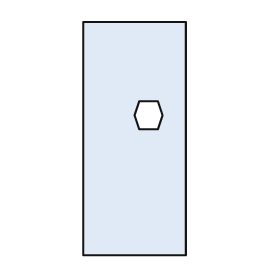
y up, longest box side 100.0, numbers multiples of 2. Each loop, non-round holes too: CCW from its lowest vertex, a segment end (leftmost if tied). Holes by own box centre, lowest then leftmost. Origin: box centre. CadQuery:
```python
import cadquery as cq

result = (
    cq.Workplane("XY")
    .moveTo(-22.0, -50.0)
    .lineTo(22.0, -50.0)
    .lineTo(22.0, 50.0)
    .lineTo(-22.0, 50.0)
    .close()
    .moveTo(2.0, 4.0)
    .lineTo(10.0, 4.0)
    .lineTo(12.0, 10.0)
    .lineTo(10.0, 16.0)
    .lineTo(2.0, 16.0)
    .lineTo(0.0, 10.0)
    .close()
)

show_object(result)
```